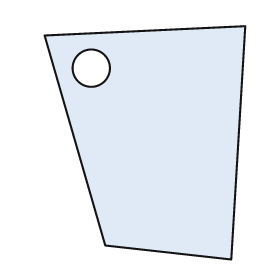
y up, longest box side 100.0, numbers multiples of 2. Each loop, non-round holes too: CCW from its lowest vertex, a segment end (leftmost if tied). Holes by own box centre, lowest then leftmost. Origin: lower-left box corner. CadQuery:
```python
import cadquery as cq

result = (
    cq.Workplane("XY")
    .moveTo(80.0, 0.0)
    .lineTo(86.0, 100.0)
    .lineTo(0.0, 96.0)
    .lineTo(26.0, 6.0)
    .close()
    .moveTo(20.0, 82.0)
    .circle(8.0)
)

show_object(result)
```